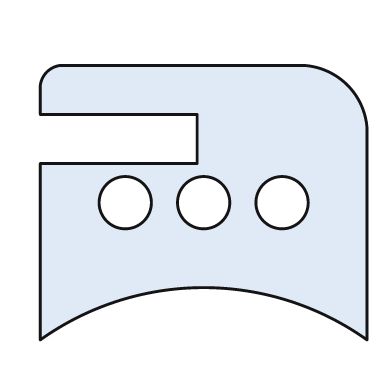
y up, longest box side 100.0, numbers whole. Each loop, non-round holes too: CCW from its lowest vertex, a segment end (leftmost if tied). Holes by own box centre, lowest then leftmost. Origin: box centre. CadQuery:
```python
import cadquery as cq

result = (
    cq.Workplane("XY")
    .moveTo(-50.0, -42.0)
    .threePointArc((0.0, -26.0), (50.0, -42.0))
    .lineTo(50.0, 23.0)
    .threePointArc((44.0, 36.0), (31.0, 42.0))
    .lineTo(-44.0, 42.0)
    .threePointArc((-48.0, 40.0), (-50.0, 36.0))
    .lineTo(-50.0, 27.0)
    .lineTo(-2.0, 27.0)
    .lineTo(-2.0, 12.0)
    .lineTo(-50.0, 12.0)
    .close()
    .moveTo(-24.0, 0.0)
    .circle(8.0)
    .moveTo(0.0, 0.0)
    .circle(8.0)
    .moveTo(24.0, 0.0)
    .circle(8.0)
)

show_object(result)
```